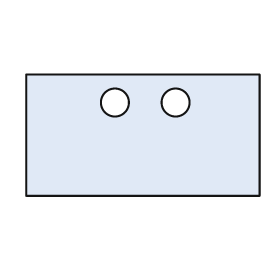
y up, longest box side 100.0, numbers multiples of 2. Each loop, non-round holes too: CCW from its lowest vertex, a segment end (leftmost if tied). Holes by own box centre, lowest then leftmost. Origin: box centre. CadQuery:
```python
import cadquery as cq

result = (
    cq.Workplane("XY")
    .moveTo(-50.0, -26.0)
    .lineTo(50.0, -26.0)
    .lineTo(50.0, 26.0)
    .lineTo(-50.0, 26.0)
    .close()
    .moveTo(-12.0, 14.0)
    .circle(6.0)
    .moveTo(14.0, 14.0)
    .circle(6.0)
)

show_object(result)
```